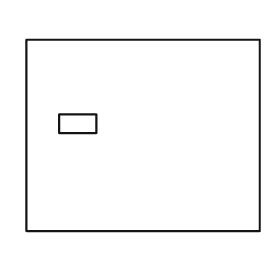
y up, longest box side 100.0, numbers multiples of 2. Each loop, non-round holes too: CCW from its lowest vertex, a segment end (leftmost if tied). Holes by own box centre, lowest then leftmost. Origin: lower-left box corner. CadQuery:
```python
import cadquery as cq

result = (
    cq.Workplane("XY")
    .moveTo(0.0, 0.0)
    .lineTo(100.0, 0.0)
    .lineTo(100.0, 82.0)
    .lineTo(0.0, 82.0)
    .close()
    .moveTo(14.0, 42.0)
    .lineTo(30.0, 42.0)
    .lineTo(30.0, 50.0)
    .lineTo(14.0, 50.0)
    .close()
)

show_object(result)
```